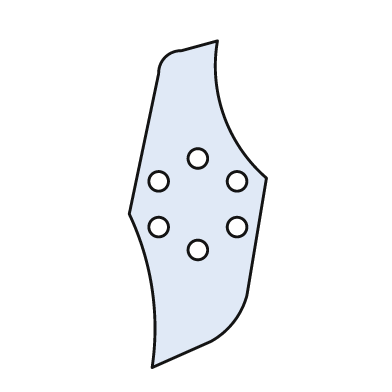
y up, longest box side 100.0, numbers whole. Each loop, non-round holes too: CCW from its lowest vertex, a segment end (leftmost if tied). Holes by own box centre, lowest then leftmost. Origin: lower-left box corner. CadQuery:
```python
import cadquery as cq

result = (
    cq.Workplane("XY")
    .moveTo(7.0, 0.0)
    .lineTo(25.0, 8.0)
    .threePointArc((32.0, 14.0), (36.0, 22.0))
    .lineTo(42.0, 58.0)
    .threePointArc((29.0, 77.0), (27.0, 100.0))
    .lineTo(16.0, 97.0)
    .threePointArc((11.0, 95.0), (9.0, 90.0))
    .lineTo(0.0, 47.0)
    .threePointArc((7.0, 24.0), (7.0, 0.0))
    .close()
    .moveTo(21.0, 36.0)
    .circle(3.0)
    .moveTo(9.0, 43.0)
    .circle(3.0)
    .moveTo(33.0, 43.0)
    .circle(3.0)
    .moveTo(9.0, 57.0)
    .circle(3.0)
    .moveTo(33.0, 57.0)
    .circle(3.0)
    .moveTo(21.0, 64.0)
    .circle(3.0)
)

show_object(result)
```